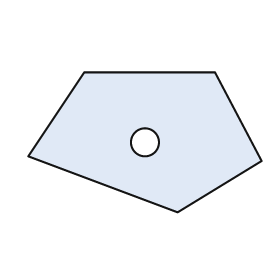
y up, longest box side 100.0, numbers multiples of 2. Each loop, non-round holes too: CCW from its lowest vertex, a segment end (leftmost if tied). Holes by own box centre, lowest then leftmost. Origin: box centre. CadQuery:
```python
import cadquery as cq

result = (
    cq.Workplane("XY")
    .moveTo(14.0, -30.0)
    .lineTo(50.0, -8.0)
    .lineTo(30.0, 30.0)
    .lineTo(-26.0, 30.0)
    .lineTo(-50.0, -6.0)
    .close()
    .moveTo(0.0, 0.0)
    .circle(6.0)
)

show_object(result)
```